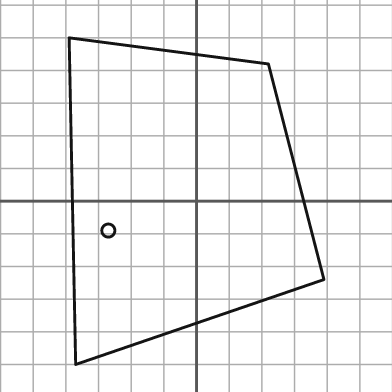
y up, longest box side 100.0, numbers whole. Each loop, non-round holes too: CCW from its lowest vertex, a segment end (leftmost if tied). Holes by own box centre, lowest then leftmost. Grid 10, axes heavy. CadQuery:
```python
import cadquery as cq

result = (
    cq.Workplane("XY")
    .moveTo(-37.0, -50.0)
    .lineTo(39.0, -24.0)
    .lineTo(22.0, 42.0)
    .lineTo(-39.0, 50.0)
    .close()
    .moveTo(-27.0, -9.0)
    .circle(2.0)
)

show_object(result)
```